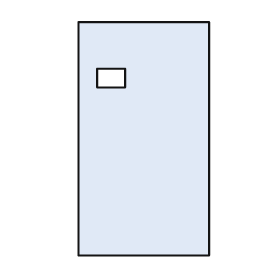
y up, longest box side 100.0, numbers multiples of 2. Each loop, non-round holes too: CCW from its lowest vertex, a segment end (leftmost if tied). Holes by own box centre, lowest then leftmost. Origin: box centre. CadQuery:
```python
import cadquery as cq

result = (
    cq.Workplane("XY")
    .moveTo(-28.0, -50.0)
    .lineTo(28.0, -50.0)
    .lineTo(28.0, 50.0)
    .lineTo(-28.0, 50.0)
    .close()
    .moveTo(-20.0, 22.0)
    .lineTo(-8.0, 22.0)
    .lineTo(-8.0, 30.0)
    .lineTo(-20.0, 30.0)
    .close()
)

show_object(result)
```